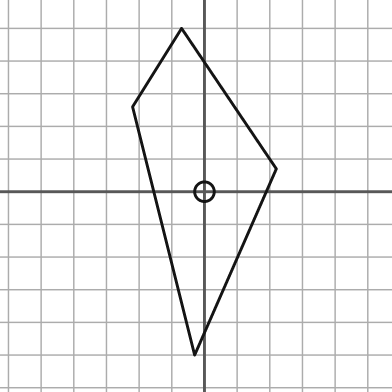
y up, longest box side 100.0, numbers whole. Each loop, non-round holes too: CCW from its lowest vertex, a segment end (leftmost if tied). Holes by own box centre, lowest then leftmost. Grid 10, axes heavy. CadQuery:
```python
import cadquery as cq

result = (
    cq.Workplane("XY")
    .moveTo(-3.0, -50.0)
    .lineTo(22.0, 7.0)
    .lineTo(-7.0, 50.0)
    .lineTo(-22.0, 26.0)
    .close()
    .moveTo(0.0, 0.0)
    .circle(3.0)
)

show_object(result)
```